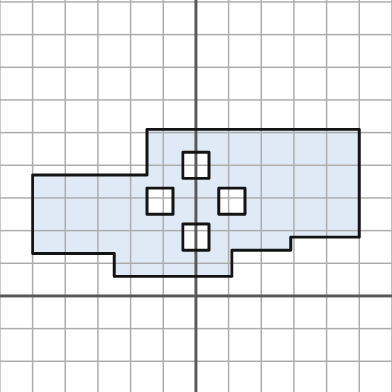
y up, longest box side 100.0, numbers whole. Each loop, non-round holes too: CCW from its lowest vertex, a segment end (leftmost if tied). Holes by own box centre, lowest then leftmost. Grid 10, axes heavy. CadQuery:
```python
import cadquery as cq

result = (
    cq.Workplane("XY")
    .moveTo(-25.0, 6.0)
    .lineTo(11.0, 6.0)
    .lineTo(11.0, 14.0)
    .lineTo(29.0, 14.0)
    .lineTo(29.0, 18.0)
    .lineTo(50.0, 18.0)
    .lineTo(50.0, 51.0)
    .lineTo(-15.0, 51.0)
    .lineTo(-15.0, 37.0)
    .lineTo(-50.0, 37.0)
    .lineTo(-50.0, 13.0)
    .lineTo(-25.0, 13.0)
    .close()
    .moveTo(-4.0, 14.0)
    .lineTo(4.0, 14.0)
    .lineTo(4.0, 22.0)
    .lineTo(-4.0, 22.0)
    .close()
    .moveTo(-15.0, 25.0)
    .lineTo(-7.0, 25.0)
    .lineTo(-7.0, 33.0)
    .lineTo(-15.0, 33.0)
    .close()
    .moveTo(7.0, 25.0)
    .lineTo(15.0, 25.0)
    .lineTo(15.0, 33.0)
    .lineTo(7.0, 33.0)
    .close()
    .moveTo(-4.0, 36.0)
    .lineTo(4.0, 36.0)
    .lineTo(4.0, 44.0)
    .lineTo(-4.0, 44.0)
    .close()
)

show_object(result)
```